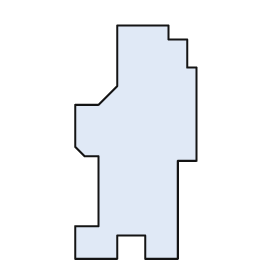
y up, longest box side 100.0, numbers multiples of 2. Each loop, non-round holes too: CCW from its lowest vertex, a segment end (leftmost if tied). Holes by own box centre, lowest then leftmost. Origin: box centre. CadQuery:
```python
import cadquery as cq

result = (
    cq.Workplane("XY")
    .moveTo(-26.0, -50.0)
    .lineTo(-8.0, -50.0)
    .lineTo(-8.0, -40.0)
    .lineTo(4.0, -40.0)
    .lineTo(4.0, -50.0)
    .lineTo(18.0, -50.0)
    .lineTo(18.0, -8.0)
    .lineTo(26.0, -8.0)
    .lineTo(26.0, 32.0)
    .lineTo(22.0, 32.0)
    .lineTo(22.0, 44.0)
    .lineTo(14.0, 44.0)
    .lineTo(14.0, 50.0)
    .lineTo(-8.0, 50.0)
    .lineTo(-8.0, 24.0)
    .lineTo(-16.0, 16.0)
    .lineTo(-26.0, 16.0)
    .lineTo(-26.0, -2.0)
    .lineTo(-22.0, -6.0)
    .lineTo(-16.0, -6.0)
    .lineTo(-16.0, -36.0)
    .lineTo(-26.0, -36.0)
    .close()
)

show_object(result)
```